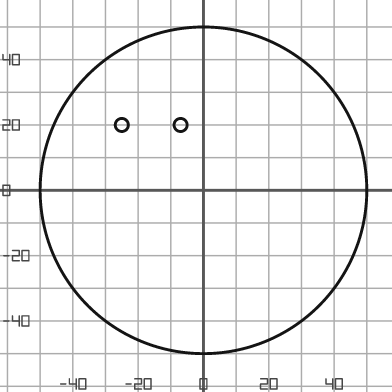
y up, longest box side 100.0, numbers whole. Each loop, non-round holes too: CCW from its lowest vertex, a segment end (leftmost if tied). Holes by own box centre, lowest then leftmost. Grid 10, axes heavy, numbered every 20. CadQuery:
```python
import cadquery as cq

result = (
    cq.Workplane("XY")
    .moveTo(0.0, 0.0)
    .circle(50.0)
    .moveTo(-25.0, 20.0)
    .circle(2.0)
    .moveTo(-7.0, 20.0)
    .circle(2.0)
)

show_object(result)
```